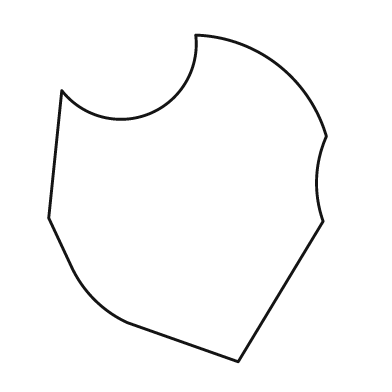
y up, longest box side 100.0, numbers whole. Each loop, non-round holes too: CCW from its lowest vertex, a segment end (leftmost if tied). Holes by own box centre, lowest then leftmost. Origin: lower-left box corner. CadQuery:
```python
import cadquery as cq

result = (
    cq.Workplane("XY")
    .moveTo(58.0, 0.0)
    .lineTo(84.0, 43.0)
    .threePointArc((82.0, 56.0), (85.0, 69.0))
    .threePointArc((70.0, 91.0), (45.0, 100.0))
    .threePointArc((31.0, 76.0), (4.0, 83.0))
    .lineTo(0.0, 44.0)
    .lineTo(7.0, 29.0)
    .threePointArc((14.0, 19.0), (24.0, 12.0))
    .close()
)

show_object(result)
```